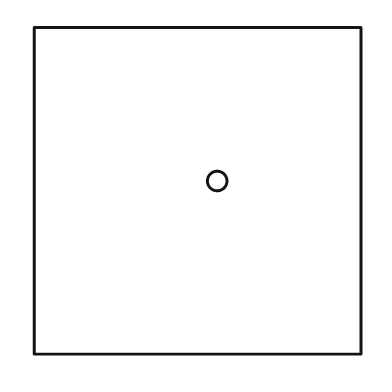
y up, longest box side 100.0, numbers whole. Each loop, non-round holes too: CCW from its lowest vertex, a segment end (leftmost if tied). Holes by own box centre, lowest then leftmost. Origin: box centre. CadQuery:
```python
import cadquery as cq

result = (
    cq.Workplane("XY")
    .moveTo(-50.0, -50.0)
    .lineTo(50.0, -50.0)
    .lineTo(50.0, 50.0)
    .lineTo(-50.0, 50.0)
    .close()
    .moveTo(6.0, 3.0)
    .circle(3.0)
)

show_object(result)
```